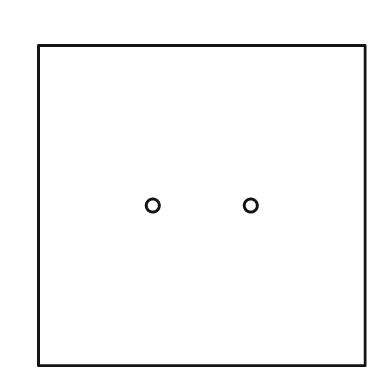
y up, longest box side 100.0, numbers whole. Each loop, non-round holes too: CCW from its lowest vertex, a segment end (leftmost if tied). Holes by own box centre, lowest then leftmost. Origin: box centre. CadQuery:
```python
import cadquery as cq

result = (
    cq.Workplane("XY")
    .moveTo(-50.0, -49.0)
    .lineTo(50.0, -49.0)
    .lineTo(50.0, 49.0)
    .lineTo(-50.0, 49.0)
    .close()
    .moveTo(-15.0, 0.0)
    .circle(2.0)
    .moveTo(15.0, 0.0)
    .circle(2.0)
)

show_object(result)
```